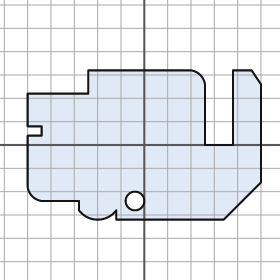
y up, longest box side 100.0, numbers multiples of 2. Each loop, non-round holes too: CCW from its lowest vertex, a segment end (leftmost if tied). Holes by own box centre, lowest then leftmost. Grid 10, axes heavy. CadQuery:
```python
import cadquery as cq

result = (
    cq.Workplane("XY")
    .moveTo(-12.0, -32.0)
    .lineTo(34.0, -32.0)
    .lineTo(50.0, -16.0)
    .lineTo(50.0, 26.0)
    .lineTo(46.0, 32.0)
    .lineTo(38.0, 32.0)
    .lineTo(38.0, 0.0)
    .lineTo(26.0, 0.0)
    .lineTo(26.0, 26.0)
    .threePointArc((24.0, 30.0), (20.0, 32.0))
    .lineTo(-24.0, 32.0)
    .lineTo(-24.0, 22.0)
    .lineTo(-50.0, 22.0)
    .lineTo(-50.0, 8.0)
    .lineTo(-44.0, 8.0)
    .lineTo(-44.0, 4.0)
    .lineTo(-50.0, 4.0)
    .lineTo(-50.0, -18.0)
    .threePointArc((-48.0, -22.0), (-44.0, -24.0))
    .lineTo(-28.0, -24.0)
    .lineTo(-28.0, -28.0)
    .threePointArc((-20.0, -32.0), (-12.0, -28.0))
    .close()
    .moveTo(-4.0, -24.0)
    .circle(4.0)
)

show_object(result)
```